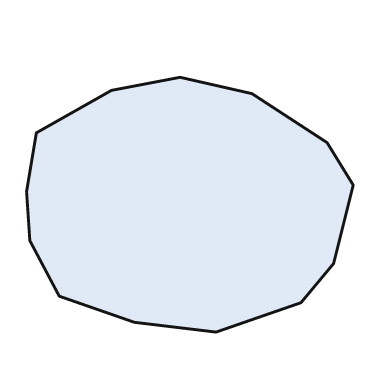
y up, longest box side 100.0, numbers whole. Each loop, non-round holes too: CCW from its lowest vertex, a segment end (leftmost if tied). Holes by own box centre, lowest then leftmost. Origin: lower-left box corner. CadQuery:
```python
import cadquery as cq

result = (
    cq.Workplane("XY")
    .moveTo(58.0, 0.0)
    .lineTo(84.0, 9.0)
    .lineTo(94.0, 21.0)
    .lineTo(100.0, 45.0)
    .lineTo(92.0, 58.0)
    .lineTo(69.0, 73.0)
    .lineTo(47.0, 78.0)
    .lineTo(26.0, 74.0)
    .lineTo(3.0, 61.0)
    .lineTo(0.0, 43.0)
    .lineTo(1.0, 28.0)
    .lineTo(10.0, 11.0)
    .lineTo(33.0, 3.0)
    .close()
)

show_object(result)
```